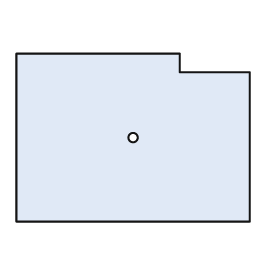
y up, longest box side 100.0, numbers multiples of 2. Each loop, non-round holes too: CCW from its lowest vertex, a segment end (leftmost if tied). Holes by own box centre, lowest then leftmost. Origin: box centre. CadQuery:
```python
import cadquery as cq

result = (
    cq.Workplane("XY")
    .moveTo(-50.0, -36.0)
    .lineTo(50.0, -36.0)
    .lineTo(50.0, 28.0)
    .lineTo(20.0, 28.0)
    .lineTo(20.0, 36.0)
    .lineTo(-50.0, 36.0)
    .close()
    .moveTo(0.0, 0.0)
    .circle(2.0)
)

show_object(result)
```